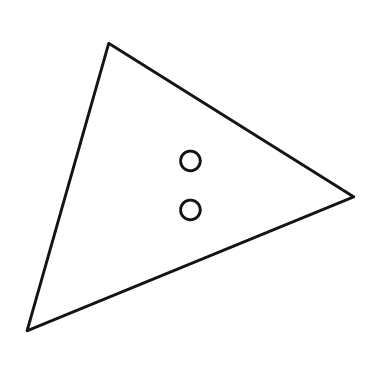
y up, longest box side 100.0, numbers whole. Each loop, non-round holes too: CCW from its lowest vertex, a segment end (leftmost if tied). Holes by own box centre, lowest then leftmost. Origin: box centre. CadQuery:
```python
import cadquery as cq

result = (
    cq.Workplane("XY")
    .moveTo(-50.0, -44.0)
    .lineTo(50.0, -3.0)
    .lineTo(-25.0, 44.0)
    .close()
    .moveTo(0.0, -7.0)
    .circle(3.0)
    .moveTo(0.0, 8.0)
    .circle(3.0)
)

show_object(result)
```